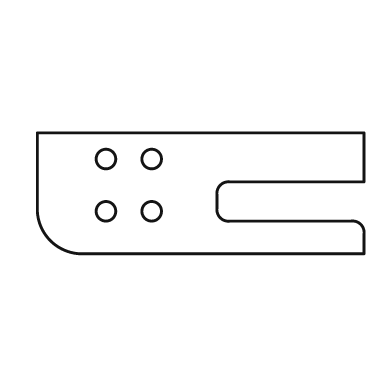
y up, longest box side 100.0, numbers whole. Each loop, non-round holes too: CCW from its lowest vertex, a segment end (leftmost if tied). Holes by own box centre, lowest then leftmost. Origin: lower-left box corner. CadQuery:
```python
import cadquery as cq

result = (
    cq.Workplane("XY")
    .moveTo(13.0, 0.0)
    .lineTo(100.0, 0.0)
    .lineTo(100.0, 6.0)
    .threePointArc((99.0, 9.0), (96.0, 10.0))
    .lineTo(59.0, 10.0)
    .threePointArc((56.0, 11.0), (55.0, 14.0))
    .lineTo(55.0, 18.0)
    .threePointArc((56.0, 21.0), (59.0, 22.0))
    .lineTo(100.0, 22.0)
    .lineTo(100.0, 37.0)
    .lineTo(0.0, 37.0)
    .lineTo(0.0, 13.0)
    .threePointArc((4.0, 4.0), (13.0, 0.0))
    .close()
    .moveTo(21.0, 13.0)
    .circle(3.0)
    .moveTo(35.0, 13.0)
    .circle(3.0)
    .moveTo(21.0, 29.0)
    .circle(3.0)
    .moveTo(35.0, 29.0)
    .circle(3.0)
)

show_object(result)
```